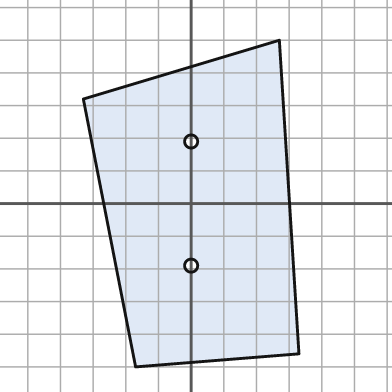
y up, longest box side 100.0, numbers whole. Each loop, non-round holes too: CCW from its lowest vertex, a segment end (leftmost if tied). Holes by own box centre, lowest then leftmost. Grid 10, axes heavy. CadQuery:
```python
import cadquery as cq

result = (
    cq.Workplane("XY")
    .moveTo(-17.0, -50.0)
    .lineTo(33.0, -46.0)
    .lineTo(27.0, 50.0)
    .lineTo(-33.0, 32.0)
    .close()
    .moveTo(0.0, -19.0)
    .circle(2.0)
    .moveTo(0.0, 19.0)
    .circle(2.0)
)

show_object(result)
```